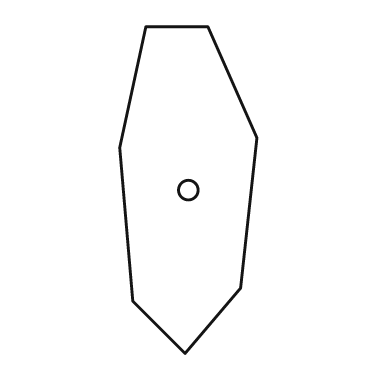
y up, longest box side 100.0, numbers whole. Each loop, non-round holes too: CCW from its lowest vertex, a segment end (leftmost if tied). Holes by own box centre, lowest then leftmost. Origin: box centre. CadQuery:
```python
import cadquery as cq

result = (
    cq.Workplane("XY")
    .moveTo(-1.0, -50.0)
    .lineTo(16.0, -30.0)
    .lineTo(21.0, 16.0)
    .lineTo(6.0, 50.0)
    .lineTo(-13.0, 50.0)
    .lineTo(-21.0, 13.0)
    .lineTo(-17.0, -34.0)
    .close()
    .moveTo(0.0, 0.0)
    .circle(3.0)
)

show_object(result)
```